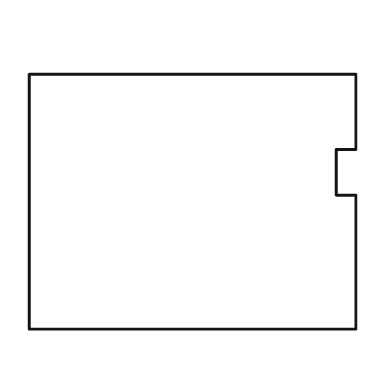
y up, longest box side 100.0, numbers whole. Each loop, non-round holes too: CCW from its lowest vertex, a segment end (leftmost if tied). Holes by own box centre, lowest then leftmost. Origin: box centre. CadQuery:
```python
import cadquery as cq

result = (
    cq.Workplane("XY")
    .moveTo(-50.0, -39.0)
    .lineTo(50.0, -39.0)
    .lineTo(50.0, 2.0)
    .lineTo(44.0, 2.0)
    .lineTo(44.0, 16.0)
    .lineTo(50.0, 16.0)
    .lineTo(50.0, 39.0)
    .lineTo(-50.0, 39.0)
    .close()
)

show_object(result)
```